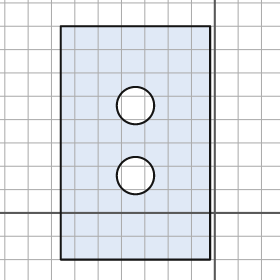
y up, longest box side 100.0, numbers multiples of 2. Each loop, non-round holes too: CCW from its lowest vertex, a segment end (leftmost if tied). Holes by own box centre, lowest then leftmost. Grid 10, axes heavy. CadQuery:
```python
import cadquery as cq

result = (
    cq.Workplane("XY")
    .moveTo(-66.0, -20.0)
    .lineTo(-2.0, -20.0)
    .lineTo(-2.0, 80.0)
    .lineTo(-66.0, 80.0)
    .close()
    .moveTo(-34.0, 16.0)
    .circle(8.0)
    .moveTo(-34.0, 46.0)
    .circle(8.0)
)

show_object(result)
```